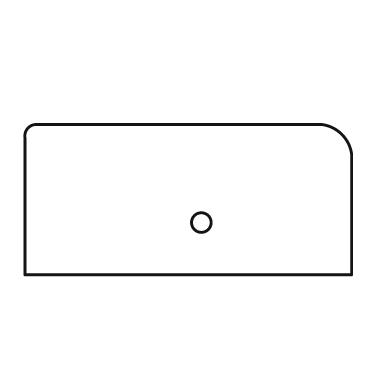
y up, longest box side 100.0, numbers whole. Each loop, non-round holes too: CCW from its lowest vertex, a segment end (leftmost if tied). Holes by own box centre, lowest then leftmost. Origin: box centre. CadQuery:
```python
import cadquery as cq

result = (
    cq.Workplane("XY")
    .moveTo(-50.0, -23.0)
    .lineTo(50.0, -23.0)
    .lineTo(50.0, 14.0)
    .threePointArc((47.0, 20.0), (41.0, 23.0))
    .lineTo(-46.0, 23.0)
    .threePointArc((-49.0, 22.0), (-50.0, 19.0))
    .close()
    .moveTo(4.0, -7.0)
    .circle(3.0)
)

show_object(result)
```